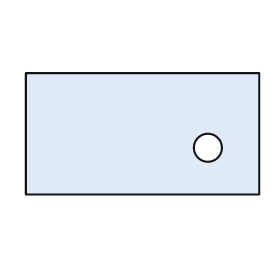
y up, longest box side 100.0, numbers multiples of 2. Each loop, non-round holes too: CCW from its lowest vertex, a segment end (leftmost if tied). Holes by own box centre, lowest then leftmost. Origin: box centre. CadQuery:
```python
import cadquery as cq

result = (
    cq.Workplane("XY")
    .moveTo(-50.0, -26.0)
    .lineTo(50.0, -26.0)
    .lineTo(50.0, 26.0)
    .lineTo(-50.0, 26.0)
    .close()
    .moveTo(28.0, -6.0)
    .circle(6.0)
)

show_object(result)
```